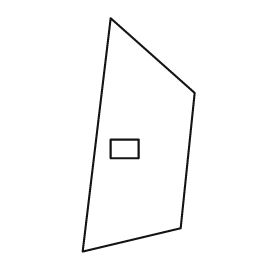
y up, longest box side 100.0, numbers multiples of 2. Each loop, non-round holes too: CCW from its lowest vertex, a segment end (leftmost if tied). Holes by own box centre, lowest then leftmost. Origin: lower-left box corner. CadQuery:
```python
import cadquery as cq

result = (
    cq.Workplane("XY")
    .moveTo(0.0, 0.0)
    .lineTo(42.0, 10.0)
    .lineTo(48.0, 68.0)
    .lineTo(12.0, 100.0)
    .close()
    .moveTo(12.0, 40.0)
    .lineTo(24.0, 40.0)
    .lineTo(24.0, 48.0)
    .lineTo(12.0, 48.0)
    .close()
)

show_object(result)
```